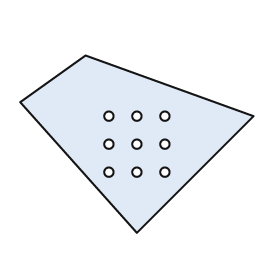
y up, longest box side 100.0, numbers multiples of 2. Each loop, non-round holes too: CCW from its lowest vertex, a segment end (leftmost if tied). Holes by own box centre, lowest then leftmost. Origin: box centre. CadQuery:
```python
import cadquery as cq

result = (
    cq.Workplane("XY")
    .moveTo(0.0, -38.0)
    .lineTo(50.0, 12.0)
    .lineTo(-22.0, 38.0)
    .lineTo(-50.0, 18.0)
    .close()
    .moveTo(-12.0, -12.0)
    .circle(2.0)
    .moveTo(0.0, -12.0)
    .circle(2.0)
    .moveTo(12.0, -12.0)
    .circle(2.0)
    .moveTo(-12.0, 0.0)
    .circle(2.0)
    .moveTo(0.0, 0.0)
    .circle(2.0)
    .moveTo(12.0, 0.0)
    .circle(2.0)
    .moveTo(-12.0, 12.0)
    .circle(2.0)
    .moveTo(0.0, 12.0)
    .circle(2.0)
    .moveTo(12.0, 12.0)
    .circle(2.0)
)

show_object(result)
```